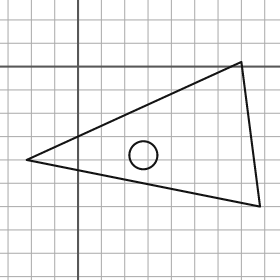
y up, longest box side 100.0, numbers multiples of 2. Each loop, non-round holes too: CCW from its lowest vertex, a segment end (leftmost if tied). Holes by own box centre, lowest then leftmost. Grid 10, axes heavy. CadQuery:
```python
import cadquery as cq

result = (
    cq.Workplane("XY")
    .moveTo(78.0, -60.0)
    .lineTo(70.0, 2.0)
    .lineTo(-22.0, -40.0)
    .close()
    .moveTo(28.0, -38.0)
    .circle(6.0)
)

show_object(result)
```